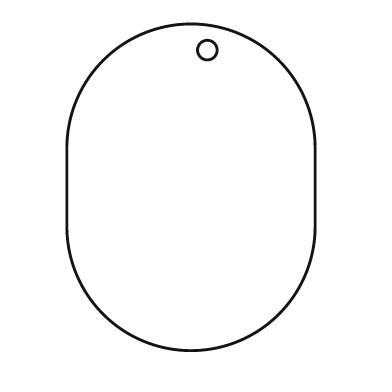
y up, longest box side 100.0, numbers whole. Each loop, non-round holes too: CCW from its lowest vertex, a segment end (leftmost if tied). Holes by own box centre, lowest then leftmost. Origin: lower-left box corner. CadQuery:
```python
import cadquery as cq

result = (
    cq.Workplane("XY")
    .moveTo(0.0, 38.0)
    .threePointArc((38.0, 0.0), (76.0, 38.0))
    .lineTo(76.0, 62.0)
    .threePointArc((38.0, 100.0), (0.0, 62.0))
    .close()
    .moveTo(43.0, 92.0)
    .circle(3.0)
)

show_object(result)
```